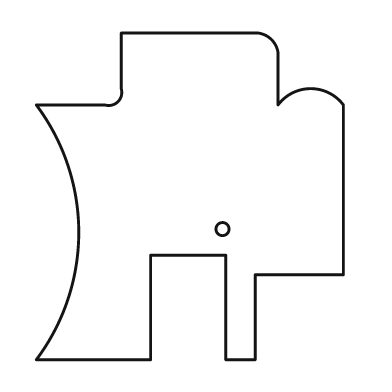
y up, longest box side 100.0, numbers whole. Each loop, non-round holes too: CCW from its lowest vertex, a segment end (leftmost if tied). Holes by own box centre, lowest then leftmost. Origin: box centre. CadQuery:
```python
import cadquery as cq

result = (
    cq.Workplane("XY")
    .moveTo(-47.0, -50.0)
    .lineTo(-12.0, -50.0)
    .lineTo(-12.0, -18.0)
    .lineTo(11.0, -18.0)
    .lineTo(11.0, -50.0)
    .lineTo(20.0, -50.0)
    .lineTo(20.0, -24.0)
    .lineTo(47.0, -24.0)
    .lineTo(47.0, 28.0)
    .threePointArc((37.0, 33.0), (27.0, 28.0))
    .lineTo(27.0, 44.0)
    .threePointArc((25.0, 48.0), (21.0, 50.0))
    .lineTo(-21.0, 50.0)
    .lineTo(-21.0, 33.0)
    .threePointArc((-22.0, 29.0), (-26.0, 28.0))
    .lineTo(-47.0, 28.0)
    .threePointArc((-34.0, -11.0), (-47.0, -50.0))
    .close()
    .moveTo(10.0, -10.0)
    .circle(2.0)
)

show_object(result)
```